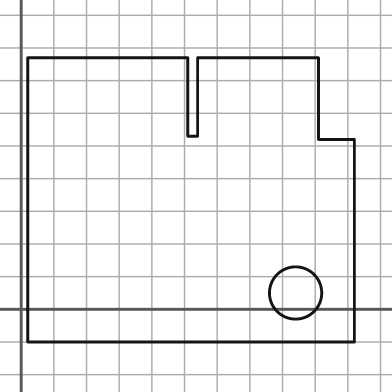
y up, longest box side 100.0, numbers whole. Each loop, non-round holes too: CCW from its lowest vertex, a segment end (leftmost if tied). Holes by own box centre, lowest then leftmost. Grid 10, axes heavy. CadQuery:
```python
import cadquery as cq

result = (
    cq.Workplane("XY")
    .moveTo(2.0, -10.0)
    .lineTo(102.0, -10.0)
    .lineTo(102.0, 52.0)
    .lineTo(91.0, 52.0)
    .lineTo(91.0, 77.0)
    .lineTo(54.0, 77.0)
    .lineTo(54.0, 53.0)
    .lineTo(51.0, 53.0)
    .lineTo(51.0, 77.0)
    .lineTo(2.0, 77.0)
    .close()
    .moveTo(84.0, 5.0)
    .circle(8.0)
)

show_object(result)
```